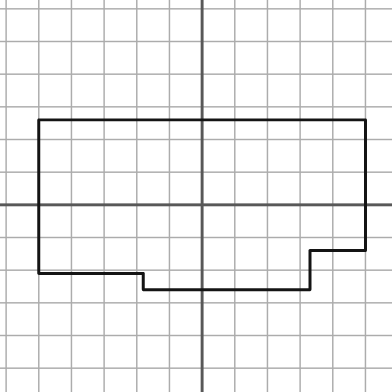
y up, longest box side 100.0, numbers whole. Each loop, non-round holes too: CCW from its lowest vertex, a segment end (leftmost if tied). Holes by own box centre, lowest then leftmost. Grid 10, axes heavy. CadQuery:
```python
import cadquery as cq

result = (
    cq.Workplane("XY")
    .moveTo(-18.0, -26.0)
    .lineTo(33.0, -26.0)
    .lineTo(33.0, -14.0)
    .lineTo(50.0, -14.0)
    .lineTo(50.0, 26.0)
    .lineTo(-50.0, 26.0)
    .lineTo(-50.0, -21.0)
    .lineTo(-18.0, -21.0)
    .close()
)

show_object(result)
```